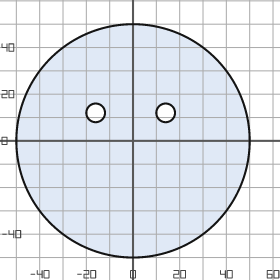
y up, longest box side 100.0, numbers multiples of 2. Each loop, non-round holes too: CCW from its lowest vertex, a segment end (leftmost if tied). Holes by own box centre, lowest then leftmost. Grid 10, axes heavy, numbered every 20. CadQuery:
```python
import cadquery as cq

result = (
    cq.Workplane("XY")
    .moveTo(0.0, 0.0)
    .circle(50.0)
    .moveTo(-16.0, 12.0)
    .circle(4.0)
    .moveTo(14.0, 12.0)
    .circle(4.0)
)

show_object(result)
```